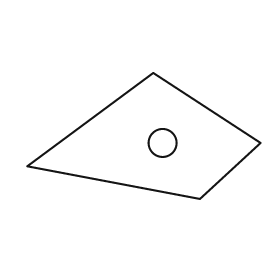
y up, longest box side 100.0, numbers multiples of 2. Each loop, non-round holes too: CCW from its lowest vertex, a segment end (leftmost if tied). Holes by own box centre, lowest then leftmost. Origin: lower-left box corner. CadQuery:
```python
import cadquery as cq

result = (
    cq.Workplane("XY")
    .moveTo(74.0, 0.0)
    .lineTo(100.0, 24.0)
    .lineTo(54.0, 54.0)
    .lineTo(0.0, 14.0)
    .close()
    .moveTo(58.0, 24.0)
    .circle(6.0)
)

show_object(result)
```